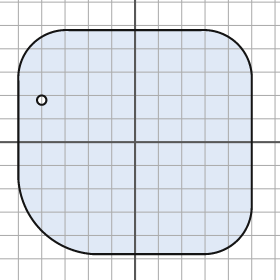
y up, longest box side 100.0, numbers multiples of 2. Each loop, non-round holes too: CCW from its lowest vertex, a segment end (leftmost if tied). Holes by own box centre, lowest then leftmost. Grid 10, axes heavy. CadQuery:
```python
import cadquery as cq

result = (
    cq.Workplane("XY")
    .moveTo(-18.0, -48.0)
    .lineTo(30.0, -48.0)
    .threePointArc((44.0, -42.0), (50.0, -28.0))
    .lineTo(50.0, 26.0)
    .threePointArc((44.0, 42.0), (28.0, 48.0))
    .lineTo(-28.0, 48.0)
    .threePointArc((-44.0, 42.0), (-50.0, 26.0))
    .lineTo(-50.0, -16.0)
    .threePointArc((-40.0, -38.0), (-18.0, -48.0))
    .close()
    .moveTo(-40.0, 18.0)
    .circle(2.0)
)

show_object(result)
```